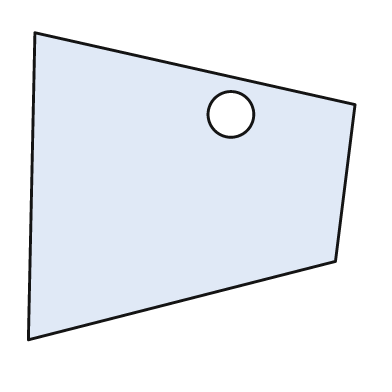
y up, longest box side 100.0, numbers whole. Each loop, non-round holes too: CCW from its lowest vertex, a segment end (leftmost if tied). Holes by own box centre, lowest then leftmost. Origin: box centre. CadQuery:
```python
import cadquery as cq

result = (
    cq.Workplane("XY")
    .moveTo(-50.0, -47.0)
    .lineTo(44.0, -23.0)
    .lineTo(50.0, 25.0)
    .lineTo(-48.0, 47.0)
    .close()
    .moveTo(12.0, 22.0)
    .circle(7.0)
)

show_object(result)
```